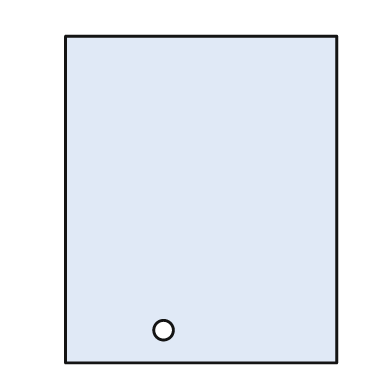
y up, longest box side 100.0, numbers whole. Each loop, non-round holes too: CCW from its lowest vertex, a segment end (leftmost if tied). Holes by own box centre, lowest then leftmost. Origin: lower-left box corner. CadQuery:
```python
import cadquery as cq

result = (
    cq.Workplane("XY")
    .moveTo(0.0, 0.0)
    .lineTo(83.0, 0.0)
    .lineTo(83.0, 100.0)
    .lineTo(0.0, 100.0)
    .close()
    .moveTo(30.0, 10.0)
    .circle(3.0)
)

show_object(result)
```